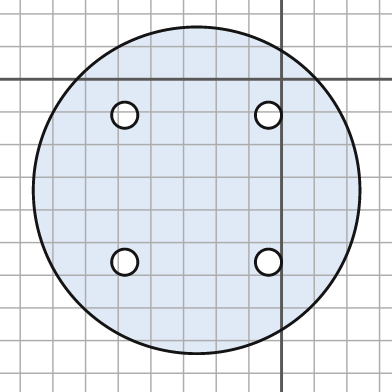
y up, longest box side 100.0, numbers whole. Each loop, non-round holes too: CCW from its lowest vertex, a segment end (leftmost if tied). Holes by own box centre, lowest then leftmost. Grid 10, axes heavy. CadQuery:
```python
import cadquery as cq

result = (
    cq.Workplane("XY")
    .moveTo(-26.0, -34.0)
    .circle(50.0)
    .moveTo(-48.0, -56.0)
    .circle(4.0)
    .moveTo(-4.0, -56.0)
    .circle(4.0)
    .moveTo(-48.0, -11.0)
    .circle(4.0)
    .moveTo(-4.0, -11.0)
    .circle(4.0)
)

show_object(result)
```